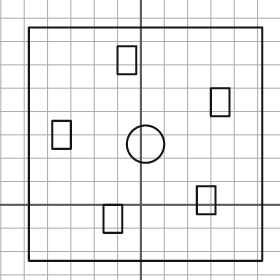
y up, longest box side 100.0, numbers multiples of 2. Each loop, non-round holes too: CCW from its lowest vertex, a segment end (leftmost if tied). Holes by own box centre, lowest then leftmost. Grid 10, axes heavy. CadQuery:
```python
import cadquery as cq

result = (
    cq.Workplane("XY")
    .moveTo(-48.0, -24.0)
    .lineTo(52.0, -24.0)
    .lineTo(52.0, 76.0)
    .lineTo(-48.0, 76.0)
    .close()
    .moveTo(-16.0, -12.0)
    .lineTo(-8.0, -12.0)
    .lineTo(-8.0, 0.0)
    .lineTo(-16.0, 0.0)
    .close()
    .moveTo(24.0, -4.0)
    .lineTo(32.0, -4.0)
    .lineTo(32.0, 8.0)
    .lineTo(24.0, 8.0)
    .close()
    .moveTo(2.0, 26.0)
    .circle(8.0)
    .moveTo(-38.0, 24.0)
    .lineTo(-30.0, 24.0)
    .lineTo(-30.0, 36.0)
    .lineTo(-38.0, 36.0)
    .close()
    .moveTo(30.0, 38.0)
    .lineTo(38.0, 38.0)
    .lineTo(38.0, 50.0)
    .lineTo(30.0, 50.0)
    .close()
    .moveTo(-10.0, 56.0)
    .lineTo(-2.0, 56.0)
    .lineTo(-2.0, 68.0)
    .lineTo(-10.0, 68.0)
    .close()
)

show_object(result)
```